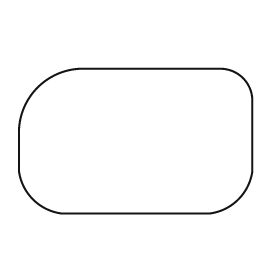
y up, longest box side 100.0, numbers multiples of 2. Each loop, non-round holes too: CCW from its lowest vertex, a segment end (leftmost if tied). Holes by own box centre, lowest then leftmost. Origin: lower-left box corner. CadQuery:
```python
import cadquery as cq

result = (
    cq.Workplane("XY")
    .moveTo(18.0, 0.0)
    .lineTo(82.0, 0.0)
    .threePointArc((94.0, 6.0), (100.0, 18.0))
    .lineTo(100.0, 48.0)
    .threePointArc((96.0, 58.0), (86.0, 62.0))
    .lineTo(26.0, 62.0)
    .threePointArc((8.0, 54.0), (0.0, 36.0))
    .lineTo(0.0, 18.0)
    .threePointArc((6.0, 6.0), (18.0, 0.0))
    .close()
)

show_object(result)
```